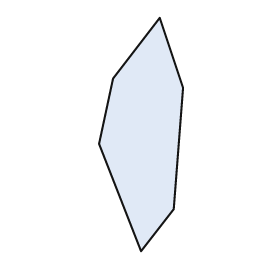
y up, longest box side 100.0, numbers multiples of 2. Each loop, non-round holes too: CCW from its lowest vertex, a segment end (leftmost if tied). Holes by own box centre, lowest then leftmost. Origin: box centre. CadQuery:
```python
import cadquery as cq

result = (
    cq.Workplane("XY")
    .moveTo(0.0, -50.0)
    .lineTo(14.0, -32.0)
    .lineTo(18.0, 20.0)
    .lineTo(8.0, 50.0)
    .lineTo(-12.0, 24.0)
    .lineTo(-18.0, -4.0)
    .close()
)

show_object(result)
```